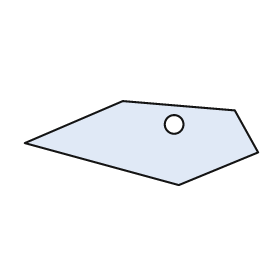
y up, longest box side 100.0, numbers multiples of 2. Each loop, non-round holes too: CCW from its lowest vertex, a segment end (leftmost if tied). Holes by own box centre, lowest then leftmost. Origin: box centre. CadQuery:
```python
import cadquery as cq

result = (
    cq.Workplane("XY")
    .moveTo(16.0, -18.0)
    .lineTo(50.0, -4.0)
    .lineTo(40.0, 14.0)
    .lineTo(-8.0, 18.0)
    .lineTo(-50.0, 0.0)
    .close()
    .moveTo(14.0, 8.0)
    .circle(4.0)
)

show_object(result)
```